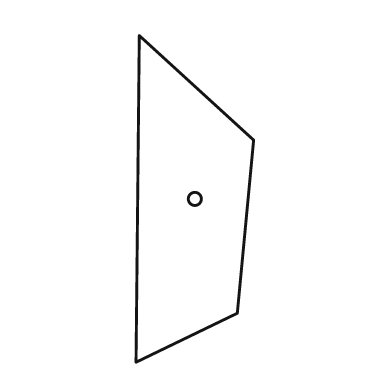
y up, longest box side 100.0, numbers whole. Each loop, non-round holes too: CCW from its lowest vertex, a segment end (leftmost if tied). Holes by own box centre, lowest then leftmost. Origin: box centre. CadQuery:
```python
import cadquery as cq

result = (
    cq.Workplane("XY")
    .moveTo(-18.0, -50.0)
    .lineTo(13.0, -35.0)
    .lineTo(18.0, 18.0)
    .lineTo(-17.0, 50.0)
    .close()
    .moveTo(0.0, 0.0)
    .circle(2.0)
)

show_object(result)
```